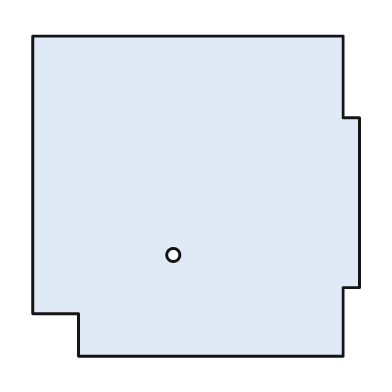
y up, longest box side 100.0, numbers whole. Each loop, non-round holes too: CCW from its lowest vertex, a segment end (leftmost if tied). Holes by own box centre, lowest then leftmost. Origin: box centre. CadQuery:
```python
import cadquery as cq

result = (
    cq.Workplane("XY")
    .moveTo(-36.0, -49.0)
    .lineTo(45.0, -49.0)
    .lineTo(45.0, -28.0)
    .lineTo(50.0, -28.0)
    .lineTo(50.0, 24.0)
    .lineTo(45.0, 24.0)
    .lineTo(45.0, 49.0)
    .lineTo(-50.0, 49.0)
    .lineTo(-50.0, -36.0)
    .lineTo(-36.0, -36.0)
    .close()
    .moveTo(-7.0, -18.0)
    .circle(2.0)
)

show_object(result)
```